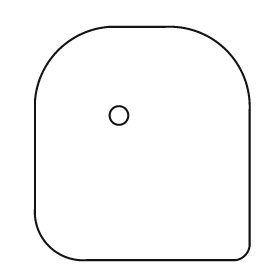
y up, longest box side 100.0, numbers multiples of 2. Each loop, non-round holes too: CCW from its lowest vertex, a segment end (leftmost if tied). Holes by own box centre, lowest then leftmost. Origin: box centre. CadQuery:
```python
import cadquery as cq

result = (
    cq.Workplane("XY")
    .moveTo(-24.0, -50.0)
    .lineTo(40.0, -50.0)
    .threePointArc((44.0, -48.0), (46.0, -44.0))
    .lineTo(46.0, 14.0)
    .threePointArc((36.0, 40.0), (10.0, 50.0))
    .lineTo(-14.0, 50.0)
    .threePointArc((-36.0, 40.0), (-46.0, 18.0))
    .lineTo(-46.0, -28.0)
    .threePointArc((-40.0, -44.0), (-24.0, -50.0))
    .close()
    .moveTo(-10.0, 12.0)
    .circle(4.0)
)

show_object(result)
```